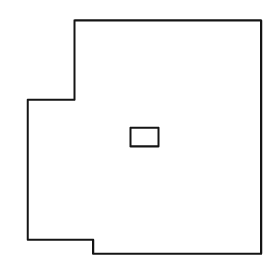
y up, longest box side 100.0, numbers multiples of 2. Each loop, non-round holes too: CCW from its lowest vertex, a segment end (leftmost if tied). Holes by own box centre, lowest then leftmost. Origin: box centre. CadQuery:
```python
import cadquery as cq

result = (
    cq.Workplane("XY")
    .moveTo(-22.0, -50.0)
    .lineTo(50.0, -50.0)
    .lineTo(50.0, 50.0)
    .lineTo(-30.0, 50.0)
    .lineTo(-30.0, 16.0)
    .lineTo(-50.0, 16.0)
    .lineTo(-50.0, -44.0)
    .lineTo(-22.0, -44.0)
    .close()
    .moveTo(-6.0, -4.0)
    .lineTo(6.0, -4.0)
    .lineTo(6.0, 4.0)
    .lineTo(-6.0, 4.0)
    .close()
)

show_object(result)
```